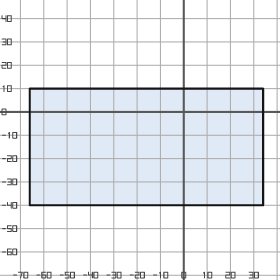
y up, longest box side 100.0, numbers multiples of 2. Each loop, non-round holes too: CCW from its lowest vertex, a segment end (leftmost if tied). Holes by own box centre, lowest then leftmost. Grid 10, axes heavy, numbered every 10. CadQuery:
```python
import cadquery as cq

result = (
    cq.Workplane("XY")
    .moveTo(-66.0, -40.0)
    .lineTo(34.0, -40.0)
    .lineTo(34.0, 10.0)
    .lineTo(-66.0, 10.0)
    .close()
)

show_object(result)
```